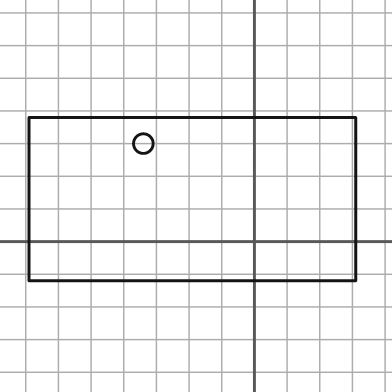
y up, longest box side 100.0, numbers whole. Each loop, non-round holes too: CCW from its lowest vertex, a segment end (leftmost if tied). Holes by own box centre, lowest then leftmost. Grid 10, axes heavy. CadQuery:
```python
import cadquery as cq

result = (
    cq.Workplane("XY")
    .moveTo(-69.0, -12.0)
    .lineTo(31.0, -12.0)
    .lineTo(31.0, 38.0)
    .lineTo(-69.0, 38.0)
    .close()
    .moveTo(-34.0, 30.0)
    .circle(3.0)
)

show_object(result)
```